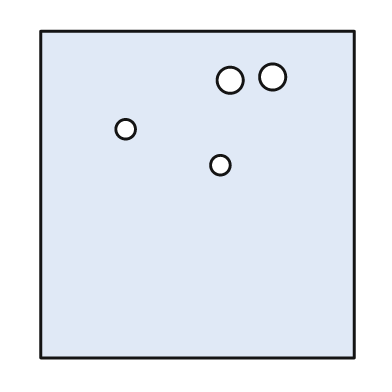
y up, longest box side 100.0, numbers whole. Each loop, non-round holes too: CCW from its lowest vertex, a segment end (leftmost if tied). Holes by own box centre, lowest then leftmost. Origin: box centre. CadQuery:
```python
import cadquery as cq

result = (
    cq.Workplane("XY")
    .moveTo(-48.0, -50.0)
    .lineTo(48.0, -50.0)
    .lineTo(48.0, 50.0)
    .lineTo(-48.0, 50.0)
    .close()
    .moveTo(7.0, 9.0)
    .circle(3.0)
    .moveTo(-22.0, 20.0)
    .circle(3.0)
    .moveTo(10.0, 35.0)
    .circle(4.0)
    .moveTo(23.0, 36.0)
    .circle(4.0)
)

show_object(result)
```